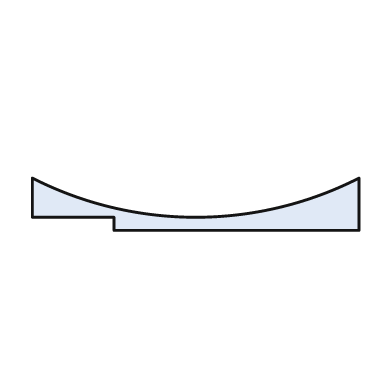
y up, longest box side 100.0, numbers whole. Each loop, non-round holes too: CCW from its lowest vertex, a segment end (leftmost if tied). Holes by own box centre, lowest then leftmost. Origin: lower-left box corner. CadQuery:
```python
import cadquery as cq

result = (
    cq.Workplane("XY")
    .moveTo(25.0, 0.0)
    .lineTo(100.0, 0.0)
    .lineTo(100.0, 16.0)
    .threePointArc((50.0, 4.0), (0.0, 16.0))
    .lineTo(0.0, 4.0)
    .lineTo(25.0, 4.0)
    .close()
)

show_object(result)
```